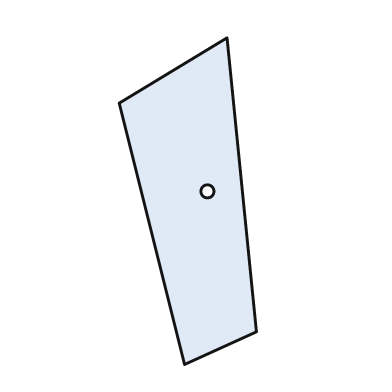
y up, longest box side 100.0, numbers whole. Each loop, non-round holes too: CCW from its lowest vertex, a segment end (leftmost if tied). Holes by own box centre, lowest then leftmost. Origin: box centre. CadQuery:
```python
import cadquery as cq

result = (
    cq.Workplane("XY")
    .moveTo(-1.0, -50.0)
    .lineTo(21.0, -40.0)
    .lineTo(12.0, 50.0)
    .lineTo(-21.0, 30.0)
    .close()
    .moveTo(6.0, 3.0)
    .circle(2.0)
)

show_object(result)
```